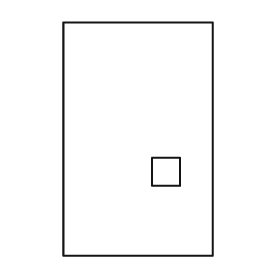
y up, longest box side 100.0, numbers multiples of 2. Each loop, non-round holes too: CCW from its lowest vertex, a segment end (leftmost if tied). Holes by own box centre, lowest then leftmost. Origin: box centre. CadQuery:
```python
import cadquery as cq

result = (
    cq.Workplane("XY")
    .moveTo(-32.0, -50.0)
    .lineTo(32.0, -50.0)
    .lineTo(32.0, 50.0)
    .lineTo(-32.0, 50.0)
    .close()
    .moveTo(6.0, -20.0)
    .lineTo(18.0, -20.0)
    .lineTo(18.0, -8.0)
    .lineTo(6.0, -8.0)
    .close()
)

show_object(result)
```